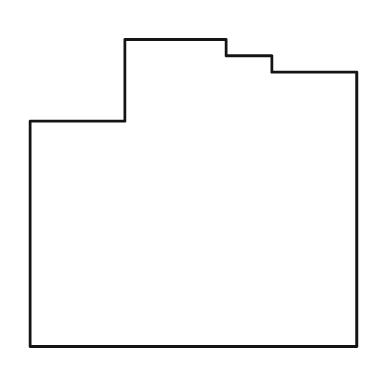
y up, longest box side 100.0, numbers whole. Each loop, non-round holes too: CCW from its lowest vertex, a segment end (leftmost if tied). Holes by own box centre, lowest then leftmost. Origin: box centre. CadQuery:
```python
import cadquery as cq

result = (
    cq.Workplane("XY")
    .moveTo(-50.0, -47.0)
    .lineTo(50.0, -47.0)
    .lineTo(50.0, 37.0)
    .lineTo(24.0, 37.0)
    .lineTo(24.0, 42.0)
    .lineTo(10.0, 42.0)
    .lineTo(10.0, 47.0)
    .lineTo(-21.0, 47.0)
    .lineTo(-21.0, 22.0)
    .lineTo(-50.0, 22.0)
    .close()
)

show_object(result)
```